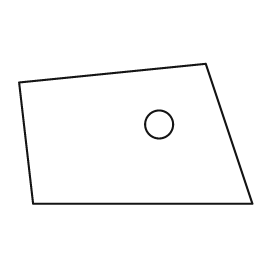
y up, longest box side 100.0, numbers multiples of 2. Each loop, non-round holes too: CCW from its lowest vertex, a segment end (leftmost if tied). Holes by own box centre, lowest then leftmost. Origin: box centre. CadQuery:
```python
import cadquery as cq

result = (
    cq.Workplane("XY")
    .moveTo(-44.0, -30.0)
    .lineTo(50.0, -30.0)
    .lineTo(30.0, 30.0)
    .lineTo(-50.0, 22.0)
    .close()
    .moveTo(10.0, 4.0)
    .circle(6.0)
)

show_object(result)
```